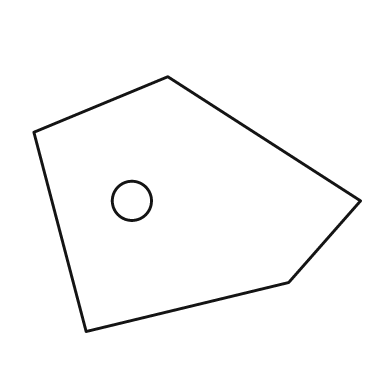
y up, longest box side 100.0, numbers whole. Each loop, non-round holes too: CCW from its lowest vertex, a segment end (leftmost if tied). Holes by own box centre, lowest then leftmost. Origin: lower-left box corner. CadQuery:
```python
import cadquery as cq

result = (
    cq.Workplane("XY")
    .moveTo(16.0, 0.0)
    .lineTo(78.0, 15.0)
    .lineTo(100.0, 40.0)
    .lineTo(41.0, 78.0)
    .lineTo(0.0, 61.0)
    .close()
    .moveTo(30.0, 40.0)
    .circle(6.0)
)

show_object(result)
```